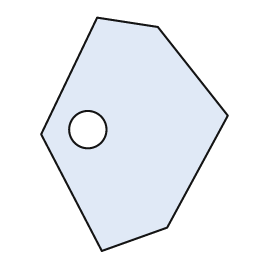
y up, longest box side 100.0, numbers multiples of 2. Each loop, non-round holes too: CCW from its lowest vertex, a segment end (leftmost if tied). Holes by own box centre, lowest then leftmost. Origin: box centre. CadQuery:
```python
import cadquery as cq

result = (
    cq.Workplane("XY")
    .moveTo(-14.0, -50.0)
    .lineTo(14.0, -40.0)
    .lineTo(40.0, 8.0)
    .lineTo(10.0, 46.0)
    .lineTo(-16.0, 50.0)
    .lineTo(-40.0, 0.0)
    .close()
    .moveTo(-20.0, 2.0)
    .circle(8.0)
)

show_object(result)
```